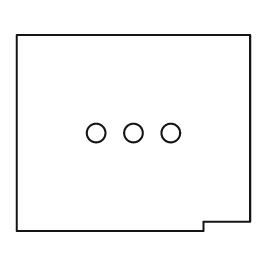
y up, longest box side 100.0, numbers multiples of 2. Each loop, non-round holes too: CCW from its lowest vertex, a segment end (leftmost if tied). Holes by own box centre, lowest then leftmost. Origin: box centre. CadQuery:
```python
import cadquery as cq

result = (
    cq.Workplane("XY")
    .moveTo(-50.0, -42.0)
    .lineTo(30.0, -42.0)
    .lineTo(30.0, -38.0)
    .lineTo(50.0, -38.0)
    .lineTo(50.0, 42.0)
    .lineTo(-50.0, 42.0)
    .close()
    .moveTo(-16.0, 0.0)
    .circle(4.0)
    .moveTo(0.0, 0.0)
    .circle(4.0)
    .moveTo(16.0, 0.0)
    .circle(4.0)
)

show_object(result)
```